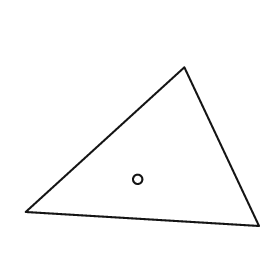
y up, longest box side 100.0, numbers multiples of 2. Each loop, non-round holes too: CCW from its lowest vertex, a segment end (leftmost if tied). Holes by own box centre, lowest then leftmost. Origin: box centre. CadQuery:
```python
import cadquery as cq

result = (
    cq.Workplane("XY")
    .moveTo(50.0, -34.0)
    .lineTo(18.0, 34.0)
    .lineTo(-50.0, -28.0)
    .close()
    .moveTo(-2.0, -14.0)
    .circle(2.0)
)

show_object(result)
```